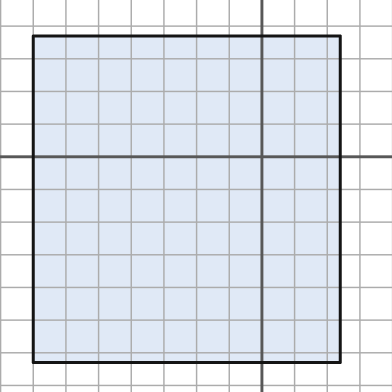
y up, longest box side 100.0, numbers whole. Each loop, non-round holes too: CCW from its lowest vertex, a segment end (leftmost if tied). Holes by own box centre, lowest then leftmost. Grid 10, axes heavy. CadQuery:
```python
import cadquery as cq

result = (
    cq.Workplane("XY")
    .moveTo(-70.0, -63.0)
    .lineTo(24.0, -63.0)
    .lineTo(24.0, 37.0)
    .lineTo(-70.0, 37.0)
    .close()
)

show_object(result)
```